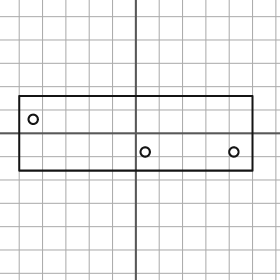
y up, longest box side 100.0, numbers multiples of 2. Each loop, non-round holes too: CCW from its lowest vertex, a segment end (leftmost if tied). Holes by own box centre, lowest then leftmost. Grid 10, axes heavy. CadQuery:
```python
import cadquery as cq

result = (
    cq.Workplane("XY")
    .moveTo(-50.0, -16.0)
    .lineTo(50.0, -16.0)
    .lineTo(50.0, 16.0)
    .lineTo(-50.0, 16.0)
    .close()
    .moveTo(4.0, -8.0)
    .circle(2.0)
    .moveTo(42.0, -8.0)
    .circle(2.0)
    .moveTo(-44.0, 6.0)
    .circle(2.0)
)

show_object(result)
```